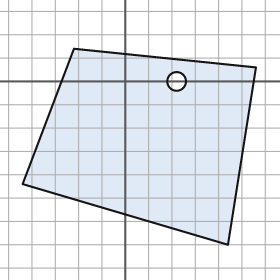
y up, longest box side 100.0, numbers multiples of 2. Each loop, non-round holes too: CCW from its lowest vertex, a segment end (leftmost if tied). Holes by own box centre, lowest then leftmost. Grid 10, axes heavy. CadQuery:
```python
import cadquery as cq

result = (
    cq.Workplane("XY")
    .moveTo(44.0, -70.0)
    .lineTo(56.0, 6.0)
    .lineTo(-22.0, 14.0)
    .lineTo(-44.0, -44.0)
    .close()
    .moveTo(22.0, 0.0)
    .circle(4.0)
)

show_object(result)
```